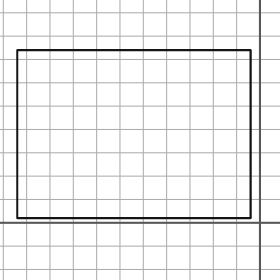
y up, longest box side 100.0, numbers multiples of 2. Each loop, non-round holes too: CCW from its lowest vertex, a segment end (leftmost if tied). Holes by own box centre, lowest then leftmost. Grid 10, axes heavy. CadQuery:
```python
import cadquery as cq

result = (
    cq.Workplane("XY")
    .moveTo(-104.0, 2.0)
    .lineTo(-4.0, 2.0)
    .lineTo(-4.0, 74.0)
    .lineTo(-104.0, 74.0)
    .close()
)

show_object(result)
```